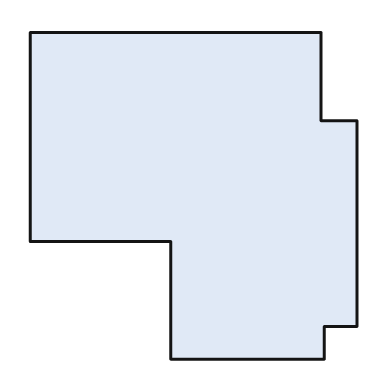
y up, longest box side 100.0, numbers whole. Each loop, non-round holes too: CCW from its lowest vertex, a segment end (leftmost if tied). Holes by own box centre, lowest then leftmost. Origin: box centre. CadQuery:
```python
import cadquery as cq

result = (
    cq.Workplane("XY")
    .moveTo(-7.0, -50.0)
    .lineTo(40.0, -50.0)
    .lineTo(40.0, -40.0)
    .lineTo(50.0, -40.0)
    .lineTo(50.0, 23.0)
    .lineTo(39.0, 23.0)
    .lineTo(39.0, 50.0)
    .lineTo(-50.0, 50.0)
    .lineTo(-50.0, -14.0)
    .lineTo(-7.0, -14.0)
    .close()
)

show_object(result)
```